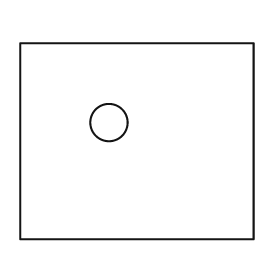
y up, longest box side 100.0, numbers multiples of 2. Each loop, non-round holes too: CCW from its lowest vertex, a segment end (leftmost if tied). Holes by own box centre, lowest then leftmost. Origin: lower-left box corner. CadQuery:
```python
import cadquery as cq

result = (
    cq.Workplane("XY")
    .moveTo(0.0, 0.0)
    .lineTo(100.0, 0.0)
    .lineTo(100.0, 84.0)
    .lineTo(0.0, 84.0)
    .close()
    .moveTo(38.0, 50.0)
    .circle(8.0)
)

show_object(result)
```